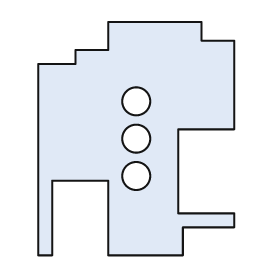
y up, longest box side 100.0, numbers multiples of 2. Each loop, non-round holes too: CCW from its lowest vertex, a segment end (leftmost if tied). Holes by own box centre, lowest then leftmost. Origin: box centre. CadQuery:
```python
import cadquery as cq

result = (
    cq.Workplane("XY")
    .moveTo(-42.0, -50.0)
    .lineTo(-36.0, -50.0)
    .lineTo(-36.0, -18.0)
    .lineTo(-12.0, -18.0)
    .lineTo(-12.0, -50.0)
    .lineTo(20.0, -50.0)
    .lineTo(20.0, -38.0)
    .lineTo(42.0, -38.0)
    .lineTo(42.0, -32.0)
    .lineTo(18.0, -32.0)
    .lineTo(18.0, 4.0)
    .lineTo(42.0, 4.0)
    .lineTo(42.0, 42.0)
    .lineTo(28.0, 42.0)
    .lineTo(28.0, 50.0)
    .lineTo(-12.0, 50.0)
    .lineTo(-12.0, 38.0)
    .lineTo(-26.0, 38.0)
    .lineTo(-26.0, 32.0)
    .lineTo(-42.0, 32.0)
    .close()
    .moveTo(0.0, -16.0)
    .circle(6.0)
    .moveTo(0.0, 0.0)
    .circle(6.0)
    .moveTo(0.0, 16.0)
    .circle(6.0)
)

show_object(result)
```